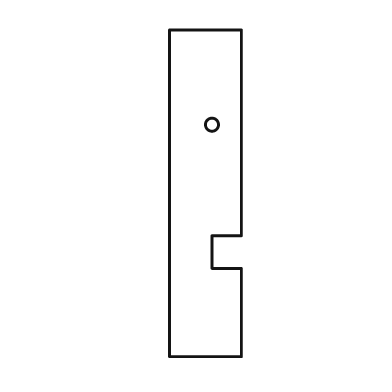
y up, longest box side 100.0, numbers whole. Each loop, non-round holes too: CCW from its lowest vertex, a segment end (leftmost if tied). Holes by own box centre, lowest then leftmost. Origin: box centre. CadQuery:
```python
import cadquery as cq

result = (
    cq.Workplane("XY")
    .moveTo(-11.0, -50.0)
    .lineTo(11.0, -50.0)
    .lineTo(11.0, -23.0)
    .lineTo(2.0, -23.0)
    .lineTo(2.0, -13.0)
    .lineTo(11.0, -13.0)
    .lineTo(11.0, 50.0)
    .lineTo(-11.0, 50.0)
    .close()
    .moveTo(2.0, 21.0)
    .circle(2.0)
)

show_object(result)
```